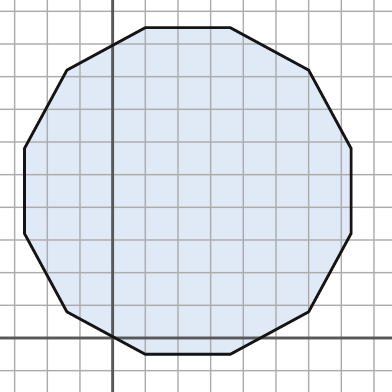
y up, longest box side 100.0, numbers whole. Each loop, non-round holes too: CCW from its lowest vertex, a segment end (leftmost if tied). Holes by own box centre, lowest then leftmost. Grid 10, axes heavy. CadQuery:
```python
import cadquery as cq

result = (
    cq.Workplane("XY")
    .moveTo(10.0, -5.0)
    .lineTo(36.0, -5.0)
    .lineTo(60.0, 8.0)
    .lineTo(73.0, 32.0)
    .lineTo(73.0, 58.0)
    .lineTo(60.0, 82.0)
    .lineTo(36.0, 95.0)
    .lineTo(10.0, 95.0)
    .lineTo(-14.0, 82.0)
    .lineTo(-27.0, 58.0)
    .lineTo(-27.0, 32.0)
    .lineTo(-14.0, 8.0)
    .close()
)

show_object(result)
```